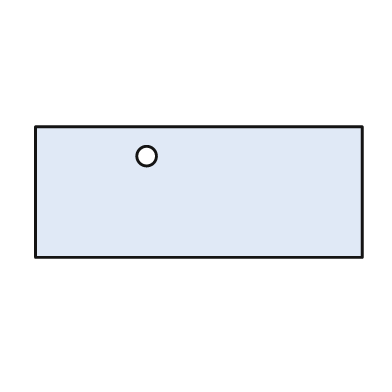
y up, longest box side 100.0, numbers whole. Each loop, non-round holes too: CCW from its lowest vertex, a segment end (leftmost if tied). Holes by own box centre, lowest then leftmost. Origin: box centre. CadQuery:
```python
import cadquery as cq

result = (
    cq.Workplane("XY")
    .moveTo(-50.0, -20.0)
    .lineTo(50.0, -20.0)
    .lineTo(50.0, 20.0)
    .lineTo(-50.0, 20.0)
    .close()
    .moveTo(-16.0, 11.0)
    .circle(3.0)
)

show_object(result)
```